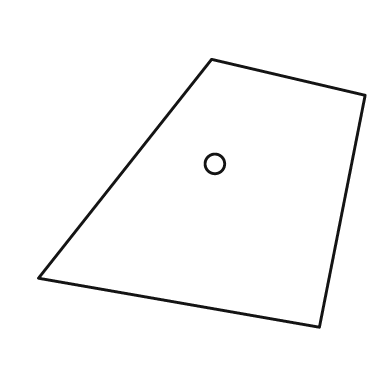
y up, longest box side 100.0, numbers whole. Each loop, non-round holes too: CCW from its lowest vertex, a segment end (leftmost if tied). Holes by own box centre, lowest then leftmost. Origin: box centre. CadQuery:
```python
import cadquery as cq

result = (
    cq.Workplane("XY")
    .moveTo(36.0, -41.0)
    .lineTo(50.0, 30.0)
    .lineTo(3.0, 41.0)
    .lineTo(-50.0, -26.0)
    .close()
    .moveTo(4.0, 9.0)
    .circle(3.0)
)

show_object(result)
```